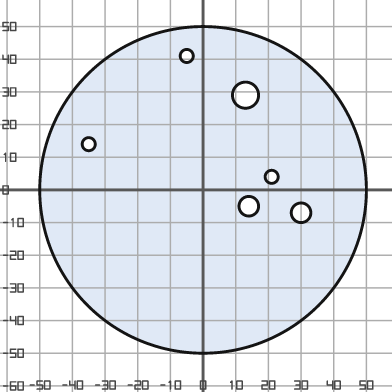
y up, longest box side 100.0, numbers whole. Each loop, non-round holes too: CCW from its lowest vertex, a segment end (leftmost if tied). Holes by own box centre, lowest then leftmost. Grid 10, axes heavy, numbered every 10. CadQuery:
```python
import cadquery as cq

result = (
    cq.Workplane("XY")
    .moveTo(0.0, 0.0)
    .circle(50.0)
    .moveTo(30.0, -7.0)
    .circle(3.0)
    .moveTo(14.0, -5.0)
    .circle(3.0)
    .moveTo(21.0, 4.0)
    .circle(2.0)
    .moveTo(-35.0, 14.0)
    .circle(2.0)
    .moveTo(13.0, 29.0)
    .circle(4.0)
    .moveTo(-5.0, 41.0)
    .circle(2.0)
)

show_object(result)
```